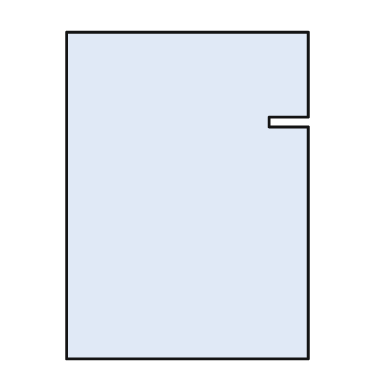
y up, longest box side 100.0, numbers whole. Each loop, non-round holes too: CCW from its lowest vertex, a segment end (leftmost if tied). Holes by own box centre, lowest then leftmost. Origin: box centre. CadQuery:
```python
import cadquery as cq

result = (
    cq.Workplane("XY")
    .moveTo(-37.0, -50.0)
    .lineTo(37.0, -50.0)
    .lineTo(37.0, 21.0)
    .lineTo(25.0, 21.0)
    .lineTo(25.0, 24.0)
    .lineTo(37.0, 24.0)
    .lineTo(37.0, 50.0)
    .lineTo(-37.0, 50.0)
    .close()
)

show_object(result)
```